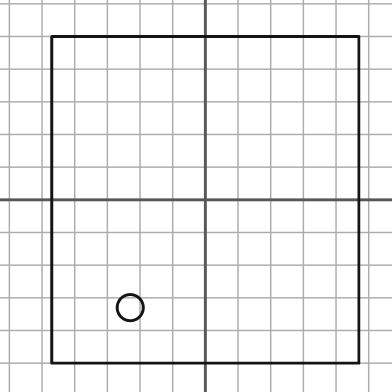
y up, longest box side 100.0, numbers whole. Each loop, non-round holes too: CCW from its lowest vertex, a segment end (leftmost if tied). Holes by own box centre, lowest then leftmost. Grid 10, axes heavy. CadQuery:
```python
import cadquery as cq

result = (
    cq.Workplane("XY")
    .moveTo(-47.0, -50.0)
    .lineTo(47.0, -50.0)
    .lineTo(47.0, 50.0)
    .lineTo(-47.0, 50.0)
    .close()
    .moveTo(-23.0, -33.0)
    .circle(4.0)
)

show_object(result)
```